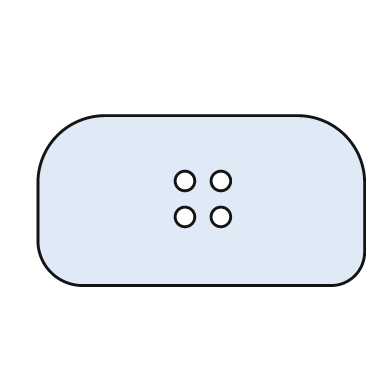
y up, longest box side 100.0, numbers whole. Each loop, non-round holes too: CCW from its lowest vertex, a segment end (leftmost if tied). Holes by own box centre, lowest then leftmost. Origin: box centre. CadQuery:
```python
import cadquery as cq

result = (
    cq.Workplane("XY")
    .moveTo(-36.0, -26.0)
    .lineTo(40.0, -26.0)
    .threePointArc((47.0, -23.0), (50.0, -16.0))
    .lineTo(50.0, 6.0)
    .threePointArc((44.0, 20.0), (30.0, 26.0))
    .lineTo(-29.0, 26.0)
    .threePointArc((-44.0, 20.0), (-50.0, 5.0))
    .lineTo(-50.0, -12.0)
    .threePointArc((-46.0, -22.0), (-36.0, -26.0))
    .close()
    .moveTo(-5.0, -5.0)
    .circle(3.0)
    .moveTo(6.0, -5.0)
    .circle(3.0)
    .moveTo(-5.0, 6.0)
    .circle(3.0)
    .moveTo(6.0, 6.0)
    .circle(3.0)
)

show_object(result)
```